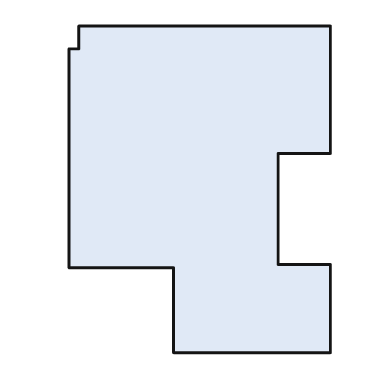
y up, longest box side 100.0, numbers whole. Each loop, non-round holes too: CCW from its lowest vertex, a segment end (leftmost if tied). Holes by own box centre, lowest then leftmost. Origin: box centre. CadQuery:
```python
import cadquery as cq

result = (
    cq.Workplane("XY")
    .moveTo(-8.0, -50.0)
    .lineTo(40.0, -50.0)
    .lineTo(40.0, -23.0)
    .lineTo(24.0, -23.0)
    .lineTo(24.0, 11.0)
    .lineTo(40.0, 11.0)
    .lineTo(40.0, 50.0)
    .lineTo(-37.0, 50.0)
    .lineTo(-37.0, 43.0)
    .lineTo(-40.0, 43.0)
    .lineTo(-40.0, -24.0)
    .lineTo(-8.0, -24.0)
    .close()
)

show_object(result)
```